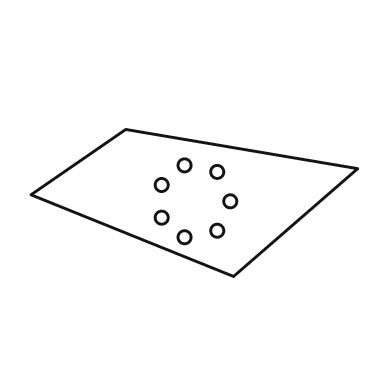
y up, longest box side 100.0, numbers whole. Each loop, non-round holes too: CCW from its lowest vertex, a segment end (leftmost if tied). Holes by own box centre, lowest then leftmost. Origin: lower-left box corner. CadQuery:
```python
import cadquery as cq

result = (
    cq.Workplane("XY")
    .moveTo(62.0, 0.0)
    .lineTo(100.0, 33.0)
    .lineTo(29.0, 45.0)
    .lineTo(0.0, 25.0)
    .close()
    .moveTo(47.0, 12.0)
    .circle(2.0)
    .moveTo(57.0, 14.0)
    .circle(2.0)
    .moveTo(40.0, 18.0)
    .circle(2.0)
    .moveTo(61.0, 23.0)
    .circle(2.0)
    .moveTo(40.0, 28.0)
    .circle(2.0)
    .moveTo(57.0, 32.0)
    .circle(2.0)
    .moveTo(47.0, 34.0)
    .circle(2.0)
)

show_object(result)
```